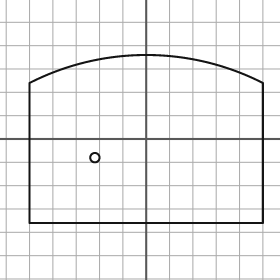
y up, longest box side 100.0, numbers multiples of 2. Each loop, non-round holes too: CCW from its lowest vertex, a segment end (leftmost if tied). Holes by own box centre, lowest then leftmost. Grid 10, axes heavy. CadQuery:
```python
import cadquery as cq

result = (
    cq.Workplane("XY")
    .moveTo(-50.0, -36.0)
    .lineTo(50.0, -36.0)
    .lineTo(50.0, 24.0)
    .threePointArc((0.0, 36.0), (-50.0, 24.0))
    .close()
    .moveTo(-22.0, -8.0)
    .circle(2.0)
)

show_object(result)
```